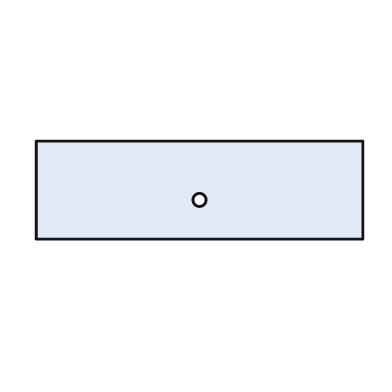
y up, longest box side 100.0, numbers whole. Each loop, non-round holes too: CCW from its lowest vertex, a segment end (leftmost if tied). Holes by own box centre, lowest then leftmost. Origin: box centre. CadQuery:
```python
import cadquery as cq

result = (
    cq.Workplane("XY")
    .moveTo(-50.0, -15.0)
    .lineTo(50.0, -15.0)
    .lineTo(50.0, 15.0)
    .lineTo(-50.0, 15.0)
    .close()
    .moveTo(0.0, -3.0)
    .circle(2.0)
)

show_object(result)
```